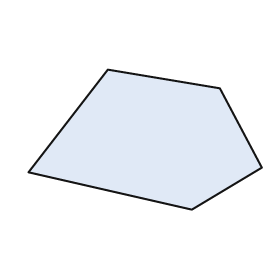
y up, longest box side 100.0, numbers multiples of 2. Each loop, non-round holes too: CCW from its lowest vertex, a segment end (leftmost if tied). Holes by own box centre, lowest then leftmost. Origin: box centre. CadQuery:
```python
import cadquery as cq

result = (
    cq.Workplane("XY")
    .moveTo(20.0, -30.0)
    .lineTo(50.0, -12.0)
    .lineTo(32.0, 22.0)
    .lineTo(-16.0, 30.0)
    .lineTo(-50.0, -14.0)
    .close()
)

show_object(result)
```